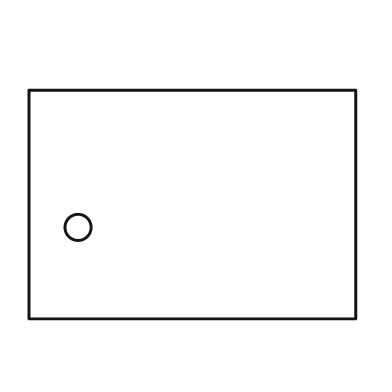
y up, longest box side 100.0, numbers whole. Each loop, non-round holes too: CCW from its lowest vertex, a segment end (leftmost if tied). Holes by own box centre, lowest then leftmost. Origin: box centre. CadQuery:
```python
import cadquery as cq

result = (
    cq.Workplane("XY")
    .moveTo(-50.0, -35.0)
    .lineTo(50.0, -35.0)
    .lineTo(50.0, 35.0)
    .lineTo(-50.0, 35.0)
    .close()
    .moveTo(-35.0, -7.0)
    .circle(4.0)
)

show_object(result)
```